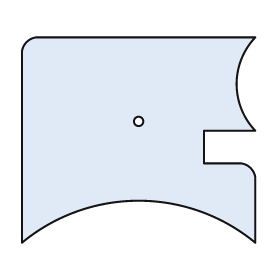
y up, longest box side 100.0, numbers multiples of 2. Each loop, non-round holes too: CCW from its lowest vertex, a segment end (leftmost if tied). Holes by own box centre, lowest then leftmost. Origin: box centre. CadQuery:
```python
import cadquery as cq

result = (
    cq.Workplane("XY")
    .moveTo(-50.0, -44.0)
    .threePointArc((0.0, -26.0), (50.0, -44.0))
    .lineTo(50.0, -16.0)
    .threePointArc((48.0, -12.0), (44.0, -10.0))
    .lineTo(28.0, -10.0)
    .lineTo(28.0, 4.0)
    .lineTo(50.0, 4.0)
    .threePointArc((42.0, 24.0), (50.0, 44.0))
    .lineTo(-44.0, 44.0)
    .threePointArc((-48.0, 42.0), (-50.0, 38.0))
    .close()
    .moveTo(0.0, 8.0)
    .circle(2.0)
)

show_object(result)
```